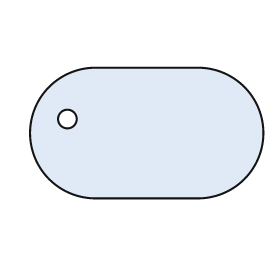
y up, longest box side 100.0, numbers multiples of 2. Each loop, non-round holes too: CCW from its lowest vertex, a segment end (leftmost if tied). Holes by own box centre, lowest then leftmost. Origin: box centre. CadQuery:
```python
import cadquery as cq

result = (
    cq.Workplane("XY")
    .moveTo(-22.0, -28.0)
    .lineTo(22.0, -28.0)
    .threePointArc((50.0, 0.0), (22.0, 28.0))
    .lineTo(-22.0, 28.0)
    .threePointArc((-50.0, 0.0), (-22.0, -28.0))
    .close()
    .moveTo(-34.0, 6.0)
    .circle(4.0)
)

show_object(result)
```